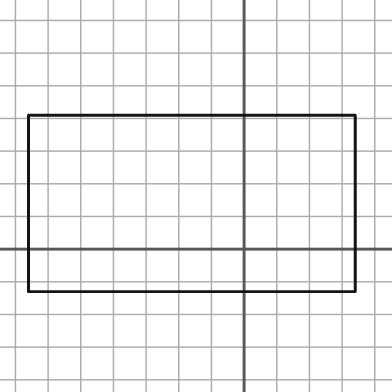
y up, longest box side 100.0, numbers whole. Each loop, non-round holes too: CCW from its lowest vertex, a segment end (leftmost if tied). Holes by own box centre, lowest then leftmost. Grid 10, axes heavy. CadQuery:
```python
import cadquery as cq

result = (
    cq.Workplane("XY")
    .moveTo(-66.0, -13.0)
    .lineTo(34.0, -13.0)
    .lineTo(34.0, 41.0)
    .lineTo(-66.0, 41.0)
    .close()
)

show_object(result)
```